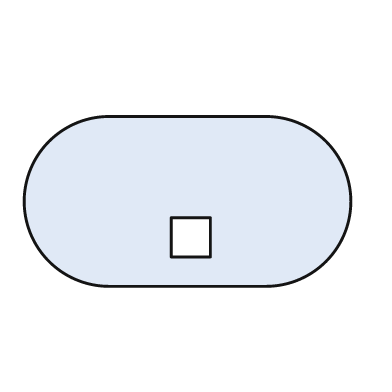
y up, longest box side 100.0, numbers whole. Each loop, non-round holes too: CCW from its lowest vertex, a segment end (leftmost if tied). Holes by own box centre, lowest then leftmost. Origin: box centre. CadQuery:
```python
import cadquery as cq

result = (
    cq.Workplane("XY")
    .moveTo(-24.0, -26.0)
    .lineTo(24.0, -26.0)
    .threePointArc((50.0, 0.0), (24.0, 26.0))
    .lineTo(-24.0, 26.0)
    .threePointArc((-50.0, 0.0), (-24.0, -26.0))
    .close()
    .moveTo(-5.0, -17.0)
    .lineTo(7.0, -17.0)
    .lineTo(7.0, -5.0)
    .lineTo(-5.0, -5.0)
    .close()
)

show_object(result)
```